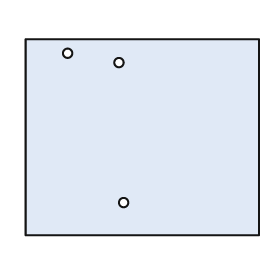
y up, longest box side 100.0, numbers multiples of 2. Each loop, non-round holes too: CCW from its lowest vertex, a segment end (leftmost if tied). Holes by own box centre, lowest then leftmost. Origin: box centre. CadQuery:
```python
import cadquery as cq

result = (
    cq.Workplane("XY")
    .moveTo(-50.0, -42.0)
    .lineTo(50.0, -42.0)
    .lineTo(50.0, 42.0)
    .lineTo(-50.0, 42.0)
    .close()
    .moveTo(-8.0, -28.0)
    .circle(2.0)
    .moveTo(-10.0, 32.0)
    .circle(2.0)
    .moveTo(-32.0, 36.0)
    .circle(2.0)
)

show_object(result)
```